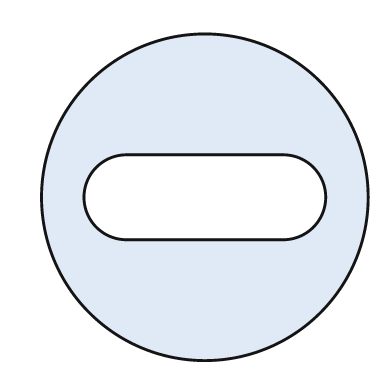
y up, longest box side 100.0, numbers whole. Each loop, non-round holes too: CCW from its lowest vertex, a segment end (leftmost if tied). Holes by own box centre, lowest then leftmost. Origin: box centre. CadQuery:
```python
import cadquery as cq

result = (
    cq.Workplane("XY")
    .moveTo(0.0, 0.0)
    .circle(50.0)
    .moveTo(-24.0, -13.0)
    .lineTo(24.0, -13.0)
    .threePointArc((37.0, 0.0), (24.0, 13.0))
    .lineTo(-24.0, 13.0)
    .threePointArc((-37.0, 0.0), (-24.0, -13.0))
    .close()
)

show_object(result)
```